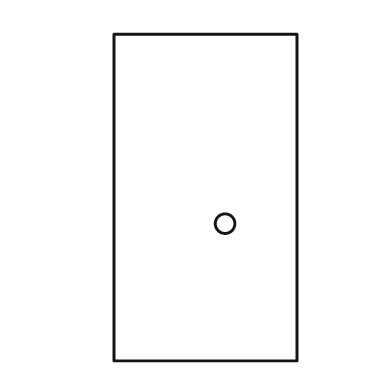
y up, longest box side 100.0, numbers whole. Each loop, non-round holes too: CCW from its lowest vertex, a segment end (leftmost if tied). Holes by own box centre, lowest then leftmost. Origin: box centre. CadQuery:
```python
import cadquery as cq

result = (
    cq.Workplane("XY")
    .moveTo(-28.0, -50.0)
    .lineTo(28.0, -50.0)
    .lineTo(28.0, 50.0)
    .lineTo(-28.0, 50.0)
    .close()
    .moveTo(6.0, -8.0)
    .circle(3.0)
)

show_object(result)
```